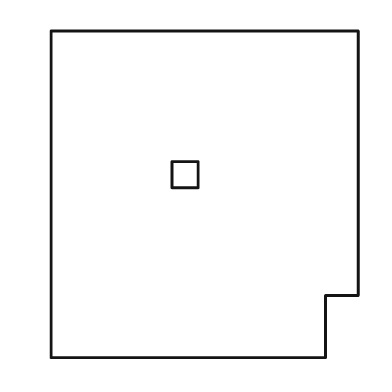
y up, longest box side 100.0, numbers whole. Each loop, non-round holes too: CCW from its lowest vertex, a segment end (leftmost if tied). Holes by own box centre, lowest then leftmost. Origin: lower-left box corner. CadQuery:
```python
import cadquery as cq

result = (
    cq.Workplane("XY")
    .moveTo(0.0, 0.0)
    .lineTo(84.0, 0.0)
    .lineTo(84.0, 19.0)
    .lineTo(94.0, 19.0)
    .lineTo(94.0, 100.0)
    .lineTo(0.0, 100.0)
    .close()
    .moveTo(37.0, 52.0)
    .lineTo(45.0, 52.0)
    .lineTo(45.0, 60.0)
    .lineTo(37.0, 60.0)
    .close()
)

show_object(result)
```